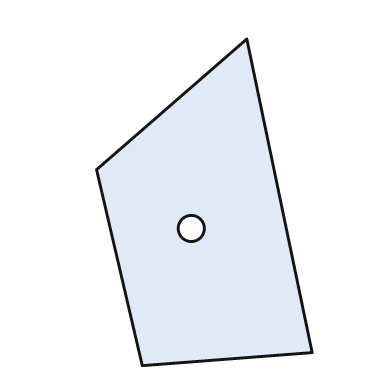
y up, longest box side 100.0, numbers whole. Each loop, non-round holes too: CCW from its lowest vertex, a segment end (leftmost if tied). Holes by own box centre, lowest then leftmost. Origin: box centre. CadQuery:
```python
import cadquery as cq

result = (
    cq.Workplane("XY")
    .moveTo(-19.0, -50.0)
    .lineTo(33.0, -46.0)
    .lineTo(13.0, 50.0)
    .lineTo(-33.0, 10.0)
    .close()
    .moveTo(-4.0, -8.0)
    .circle(4.0)
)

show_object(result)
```